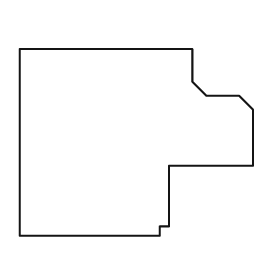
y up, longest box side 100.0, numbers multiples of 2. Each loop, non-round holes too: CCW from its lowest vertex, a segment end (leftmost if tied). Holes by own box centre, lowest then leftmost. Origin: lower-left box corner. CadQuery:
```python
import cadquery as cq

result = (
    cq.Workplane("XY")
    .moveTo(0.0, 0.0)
    .lineTo(60.0, 0.0)
    .lineTo(60.0, 4.0)
    .lineTo(64.0, 4.0)
    .lineTo(64.0, 30.0)
    .lineTo(100.0, 30.0)
    .lineTo(100.0, 54.0)
    .lineTo(94.0, 60.0)
    .lineTo(80.0, 60.0)
    .lineTo(74.0, 66.0)
    .lineTo(74.0, 80.0)
    .lineTo(0.0, 80.0)
    .close()
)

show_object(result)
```